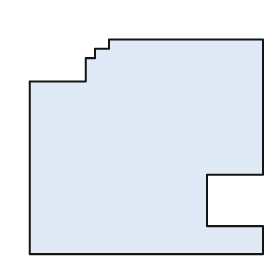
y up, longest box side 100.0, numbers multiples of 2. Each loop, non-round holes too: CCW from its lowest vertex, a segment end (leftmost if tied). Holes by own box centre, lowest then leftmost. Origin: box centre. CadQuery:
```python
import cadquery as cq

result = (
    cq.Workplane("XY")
    .moveTo(-50.0, -46.0)
    .lineTo(50.0, -46.0)
    .lineTo(50.0, -34.0)
    .lineTo(26.0, -34.0)
    .lineTo(26.0, -12.0)
    .lineTo(50.0, -12.0)
    .lineTo(50.0, 46.0)
    .lineTo(-16.0, 46.0)
    .lineTo(-16.0, 42.0)
    .lineTo(-22.0, 42.0)
    .lineTo(-22.0, 38.0)
    .lineTo(-26.0, 38.0)
    .lineTo(-26.0, 28.0)
    .lineTo(-50.0, 28.0)
    .close()
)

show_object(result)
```